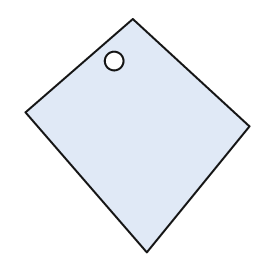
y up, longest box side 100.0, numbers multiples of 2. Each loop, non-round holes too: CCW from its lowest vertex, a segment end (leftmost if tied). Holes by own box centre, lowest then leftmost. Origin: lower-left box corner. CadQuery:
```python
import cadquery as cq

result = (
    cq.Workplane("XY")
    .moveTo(52.0, 0.0)
    .lineTo(96.0, 54.0)
    .lineTo(46.0, 100.0)
    .lineTo(0.0, 60.0)
    .close()
    .moveTo(38.0, 82.0)
    .circle(4.0)
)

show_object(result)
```